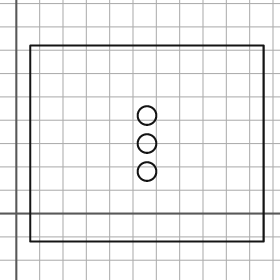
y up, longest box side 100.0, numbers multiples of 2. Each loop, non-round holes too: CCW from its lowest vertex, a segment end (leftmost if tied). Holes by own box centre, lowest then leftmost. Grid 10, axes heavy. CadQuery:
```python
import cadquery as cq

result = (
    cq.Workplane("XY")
    .moveTo(6.0, -12.0)
    .lineTo(106.0, -12.0)
    .lineTo(106.0, 72.0)
    .lineTo(6.0, 72.0)
    .close()
    .moveTo(56.0, 18.0)
    .circle(4.0)
    .moveTo(56.0, 30.0)
    .circle(4.0)
    .moveTo(56.0, 42.0)
    .circle(4.0)
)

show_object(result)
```